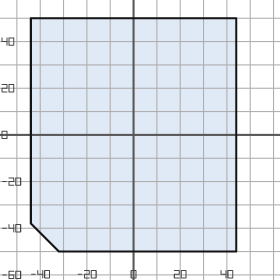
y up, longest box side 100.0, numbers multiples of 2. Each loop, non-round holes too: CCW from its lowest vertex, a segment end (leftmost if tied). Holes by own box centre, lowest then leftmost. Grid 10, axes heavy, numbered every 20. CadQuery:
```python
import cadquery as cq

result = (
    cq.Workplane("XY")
    .moveTo(-32.0, -50.0)
    .lineTo(44.0, -50.0)
    .lineTo(44.0, 50.0)
    .lineTo(-44.0, 50.0)
    .lineTo(-44.0, -38.0)
    .close()
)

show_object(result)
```